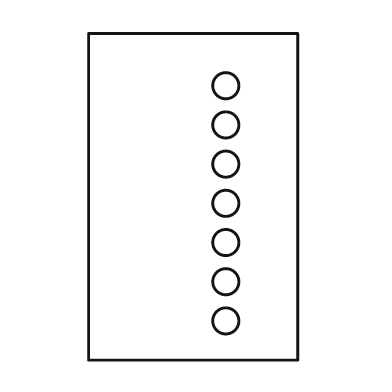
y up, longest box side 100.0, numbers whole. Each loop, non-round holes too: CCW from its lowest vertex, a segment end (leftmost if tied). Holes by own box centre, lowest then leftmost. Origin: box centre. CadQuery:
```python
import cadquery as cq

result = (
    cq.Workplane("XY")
    .moveTo(-32.0, -50.0)
    .lineTo(32.0, -50.0)
    .lineTo(32.0, 50.0)
    .lineTo(-32.0, 50.0)
    .close()
    .moveTo(10.0, -38.0)
    .circle(4.0)
    .moveTo(10.0, -26.0)
    .circle(4.0)
    .moveTo(10.0, -14.0)
    .circle(4.0)
    .moveTo(10.0, -2.0)
    .circle(4.0)
    .moveTo(10.0, 10.0)
    .circle(4.0)
    .moveTo(10.0, 22.0)
    .circle(4.0)
    .moveTo(10.0, 34.0)
    .circle(4.0)
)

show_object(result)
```